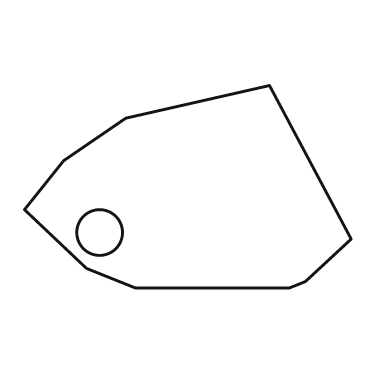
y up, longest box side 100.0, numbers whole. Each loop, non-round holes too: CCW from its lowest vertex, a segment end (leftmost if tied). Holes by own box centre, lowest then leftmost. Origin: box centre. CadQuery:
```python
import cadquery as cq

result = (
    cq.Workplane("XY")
    .moveTo(-16.0, -31.0)
    .lineTo(31.0, -31.0)
    .lineTo(36.0, -29.0)
    .lineTo(50.0, -16.0)
    .lineTo(25.0, 31.0)
    .lineTo(-19.0, 21.0)
    .lineTo(-38.0, 8.0)
    .lineTo(-50.0, -7.0)
    .lineTo(-31.0, -25.0)
    .close()
    .moveTo(-27.0, -14.0)
    .circle(7.0)
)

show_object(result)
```